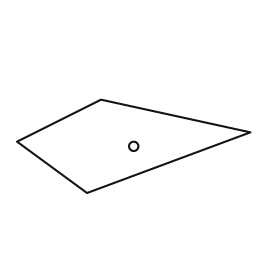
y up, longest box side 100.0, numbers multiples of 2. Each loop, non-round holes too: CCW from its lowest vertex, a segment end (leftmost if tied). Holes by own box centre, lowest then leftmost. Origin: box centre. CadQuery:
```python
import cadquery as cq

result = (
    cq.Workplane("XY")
    .moveTo(-20.0, -20.0)
    .lineTo(50.0, 6.0)
    .lineTo(-14.0, 20.0)
    .lineTo(-50.0, 2.0)
    .close()
    .moveTo(0.0, 0.0)
    .circle(2.0)
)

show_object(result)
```